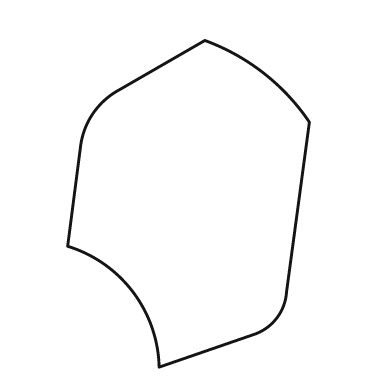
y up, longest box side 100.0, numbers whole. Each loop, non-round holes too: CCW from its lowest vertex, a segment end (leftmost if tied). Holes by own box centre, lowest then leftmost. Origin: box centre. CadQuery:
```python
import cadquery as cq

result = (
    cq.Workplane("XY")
    .moveTo(-9.0, -50.0)
    .lineTo(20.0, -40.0)
    .threePointArc((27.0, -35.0), (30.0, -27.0))
    .lineTo(37.0, 25.0)
    .threePointArc((23.0, 40.0), (5.0, 50.0))
    .lineTo(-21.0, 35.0)
    .threePointArc((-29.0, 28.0), (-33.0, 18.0))
    .lineTo(-37.0, -13.0)
    .threePointArc((-17.0, -27.0), (-9.0, -50.0))
    .close()
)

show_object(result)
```